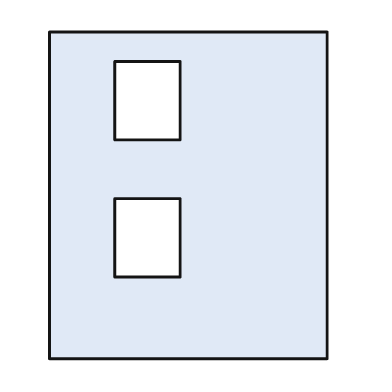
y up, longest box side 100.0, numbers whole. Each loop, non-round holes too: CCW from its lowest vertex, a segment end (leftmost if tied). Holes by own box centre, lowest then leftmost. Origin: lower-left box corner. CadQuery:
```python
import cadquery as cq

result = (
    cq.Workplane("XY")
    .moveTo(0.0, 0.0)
    .lineTo(85.0, 0.0)
    .lineTo(85.0, 100.0)
    .lineTo(0.0, 100.0)
    .close()
    .moveTo(20.0, 25.0)
    .lineTo(40.0, 25.0)
    .lineTo(40.0, 49.0)
    .lineTo(20.0, 49.0)
    .close()
    .moveTo(20.0, 67.0)
    .lineTo(40.0, 67.0)
    .lineTo(40.0, 91.0)
    .lineTo(20.0, 91.0)
    .close()
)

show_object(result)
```